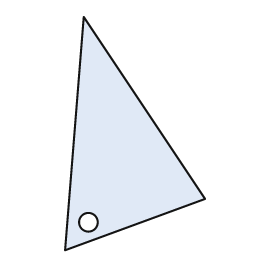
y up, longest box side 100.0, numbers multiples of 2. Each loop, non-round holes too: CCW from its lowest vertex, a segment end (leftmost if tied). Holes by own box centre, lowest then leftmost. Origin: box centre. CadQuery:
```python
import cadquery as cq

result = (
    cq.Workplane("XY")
    .moveTo(-30.0, -50.0)
    .lineTo(30.0, -28.0)
    .lineTo(-22.0, 50.0)
    .close()
    .moveTo(-20.0, -38.0)
    .circle(4.0)
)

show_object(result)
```